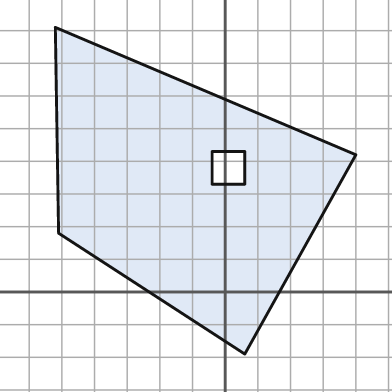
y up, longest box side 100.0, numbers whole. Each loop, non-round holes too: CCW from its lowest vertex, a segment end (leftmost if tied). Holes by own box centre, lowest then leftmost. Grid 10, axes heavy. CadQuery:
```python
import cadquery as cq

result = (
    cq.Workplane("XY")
    .moveTo(6.0, -19.0)
    .lineTo(40.0, 42.0)
    .lineTo(-52.0, 81.0)
    .lineTo(-51.0, 18.0)
    .close()
    .moveTo(-4.0, 33.0)
    .lineTo(6.0, 33.0)
    .lineTo(6.0, 43.0)
    .lineTo(-4.0, 43.0)
    .close()
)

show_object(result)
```